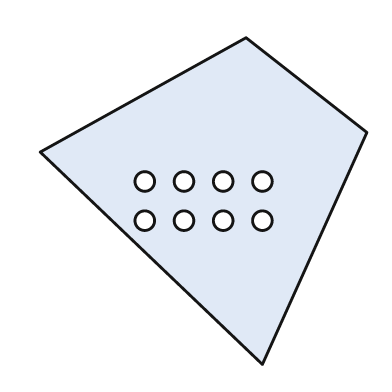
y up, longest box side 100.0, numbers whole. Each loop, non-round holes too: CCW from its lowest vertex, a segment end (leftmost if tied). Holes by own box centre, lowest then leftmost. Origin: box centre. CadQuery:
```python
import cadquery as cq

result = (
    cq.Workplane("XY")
    .moveTo(18.0, -50.0)
    .lineTo(50.0, 21.0)
    .lineTo(13.0, 50.0)
    .lineTo(-50.0, 15.0)
    .close()
    .moveTo(-18.0, -6.0)
    .circle(3.0)
    .moveTo(-6.0, -6.0)
    .circle(3.0)
    .moveTo(6.0, -6.0)
    .circle(3.0)
    .moveTo(18.0, -6.0)
    .circle(3.0)
    .moveTo(-18.0, 6.0)
    .circle(3.0)
    .moveTo(-6.0, 6.0)
    .circle(3.0)
    .moveTo(6.0, 6.0)
    .circle(3.0)
    .moveTo(18.0, 6.0)
    .circle(3.0)
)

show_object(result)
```